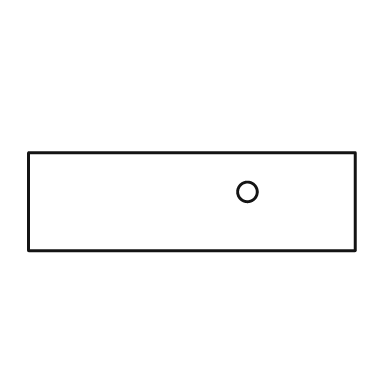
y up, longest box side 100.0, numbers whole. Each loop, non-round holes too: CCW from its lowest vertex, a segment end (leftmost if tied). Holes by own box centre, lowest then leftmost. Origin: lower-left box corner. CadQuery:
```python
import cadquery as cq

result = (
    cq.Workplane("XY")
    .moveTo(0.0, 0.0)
    .lineTo(100.0, 0.0)
    .lineTo(100.0, 30.0)
    .lineTo(0.0, 30.0)
    .close()
    .moveTo(67.0, 18.0)
    .circle(3.0)
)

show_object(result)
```